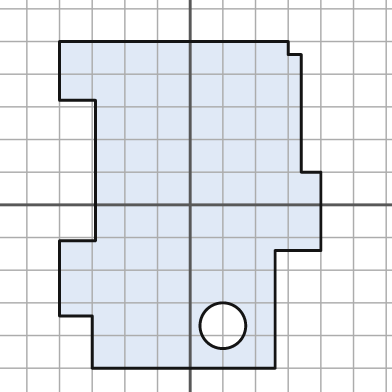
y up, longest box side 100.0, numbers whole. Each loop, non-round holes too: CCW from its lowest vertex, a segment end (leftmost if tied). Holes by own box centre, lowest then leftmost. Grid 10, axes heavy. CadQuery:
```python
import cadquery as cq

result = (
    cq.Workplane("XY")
    .moveTo(-30.0, -50.0)
    .lineTo(26.0, -50.0)
    .lineTo(26.0, -14.0)
    .lineTo(40.0, -14.0)
    .lineTo(40.0, 10.0)
    .lineTo(34.0, 10.0)
    .lineTo(34.0, 46.0)
    .lineTo(30.0, 46.0)
    .lineTo(30.0, 50.0)
    .lineTo(-40.0, 50.0)
    .lineTo(-40.0, 32.0)
    .lineTo(-29.0, 32.0)
    .lineTo(-29.0, -11.0)
    .lineTo(-40.0, -11.0)
    .lineTo(-40.0, -34.0)
    .lineTo(-30.0, -34.0)
    .close()
    .moveTo(10.0, -37.0)
    .circle(7.0)
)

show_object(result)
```